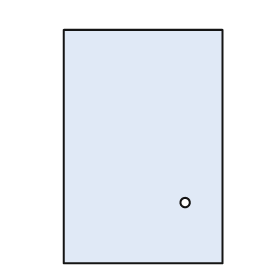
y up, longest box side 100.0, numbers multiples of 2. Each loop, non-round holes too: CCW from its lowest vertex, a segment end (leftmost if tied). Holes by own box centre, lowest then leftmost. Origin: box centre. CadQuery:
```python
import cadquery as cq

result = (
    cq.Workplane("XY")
    .moveTo(-34.0, -50.0)
    .lineTo(34.0, -50.0)
    .lineTo(34.0, 50.0)
    .lineTo(-34.0, 50.0)
    .close()
    .moveTo(18.0, -24.0)
    .circle(2.0)
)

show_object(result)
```